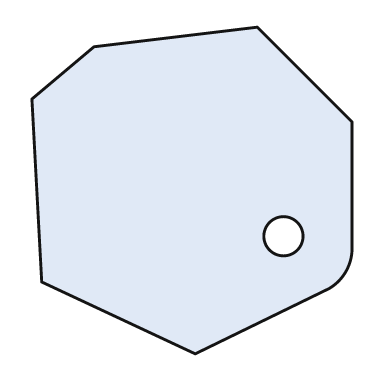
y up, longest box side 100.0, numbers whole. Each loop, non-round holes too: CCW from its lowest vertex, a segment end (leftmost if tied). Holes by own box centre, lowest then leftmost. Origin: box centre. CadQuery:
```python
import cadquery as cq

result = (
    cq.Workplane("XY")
    .moveTo(1.0, -50.0)
    .lineTo(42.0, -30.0)
    .threePointArc((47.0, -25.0), (49.0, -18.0))
    .lineTo(49.0, 21.0)
    .lineTo(20.0, 50.0)
    .lineTo(-30.0, 44.0)
    .lineTo(-49.0, 28.0)
    .lineTo(-46.0, -28.0)
    .close()
    .moveTo(28.0, -14.0)
    .circle(6.0)
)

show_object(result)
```